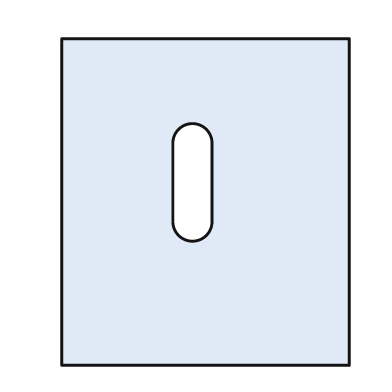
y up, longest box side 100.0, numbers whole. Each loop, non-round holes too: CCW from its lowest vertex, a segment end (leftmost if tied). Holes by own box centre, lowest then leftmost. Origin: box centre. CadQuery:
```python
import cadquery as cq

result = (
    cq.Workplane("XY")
    .moveTo(-44.0, -50.0)
    .lineTo(44.0, -50.0)
    .lineTo(44.0, 50.0)
    .lineTo(-44.0, 50.0)
    .close()
    .moveTo(-10.0, -6.0)
    .threePointArc((-4.0, -12.0), (2.0, -6.0))
    .lineTo(2.0, 18.0)
    .threePointArc((-4.0, 24.0), (-10.0, 18.0))
    .close()
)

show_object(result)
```